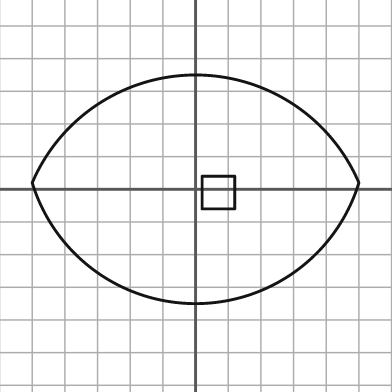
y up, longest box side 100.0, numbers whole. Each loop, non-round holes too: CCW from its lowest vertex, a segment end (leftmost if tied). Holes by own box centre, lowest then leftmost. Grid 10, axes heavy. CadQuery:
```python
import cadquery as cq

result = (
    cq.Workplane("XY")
    .moveTo(-50.0, 2.0)
    .threePointArc((0.0, -35.0), (50.0, 2.0))
    .threePointArc((0.0, 35.0), (-50.0, 2.0))
    .close()
    .moveTo(2.0, -6.0)
    .lineTo(12.0, -6.0)
    .lineTo(12.0, 4.0)
    .lineTo(2.0, 4.0)
    .close()
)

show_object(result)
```